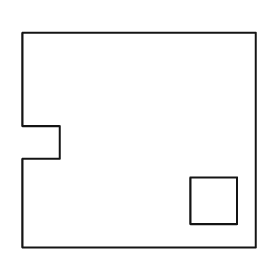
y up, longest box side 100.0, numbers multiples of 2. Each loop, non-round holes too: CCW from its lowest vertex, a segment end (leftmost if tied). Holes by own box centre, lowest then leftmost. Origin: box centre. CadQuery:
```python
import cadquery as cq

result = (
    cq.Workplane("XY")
    .moveTo(-50.0, -46.0)
    .lineTo(50.0, -46.0)
    .lineTo(50.0, 46.0)
    .lineTo(-50.0, 46.0)
    .lineTo(-50.0, 6.0)
    .lineTo(-34.0, 6.0)
    .lineTo(-34.0, -8.0)
    .lineTo(-50.0, -8.0)
    .close()
    .moveTo(22.0, -36.0)
    .lineTo(42.0, -36.0)
    .lineTo(42.0, -16.0)
    .lineTo(22.0, -16.0)
    .close()
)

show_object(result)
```